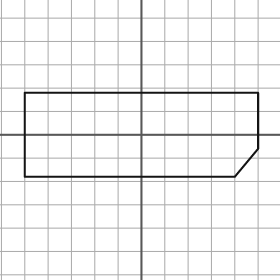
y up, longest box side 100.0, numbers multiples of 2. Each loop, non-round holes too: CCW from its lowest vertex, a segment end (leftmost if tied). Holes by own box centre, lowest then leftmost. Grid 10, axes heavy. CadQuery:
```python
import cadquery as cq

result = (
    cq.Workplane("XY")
    .moveTo(-50.0, -18.0)
    .lineTo(40.0, -18.0)
    .lineTo(50.0, -6.0)
    .lineTo(50.0, 18.0)
    .lineTo(-50.0, 18.0)
    .close()
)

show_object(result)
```